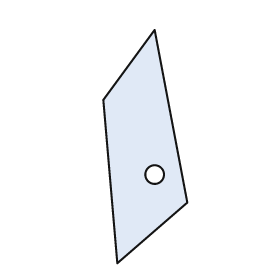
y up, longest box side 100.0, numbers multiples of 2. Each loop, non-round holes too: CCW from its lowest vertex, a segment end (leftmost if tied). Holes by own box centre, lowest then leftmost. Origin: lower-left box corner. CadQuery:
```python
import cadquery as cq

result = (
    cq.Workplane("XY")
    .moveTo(6.0, 0.0)
    .lineTo(36.0, 26.0)
    .lineTo(22.0, 100.0)
    .lineTo(0.0, 70.0)
    .close()
    .moveTo(22.0, 38.0)
    .circle(4.0)
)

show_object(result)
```